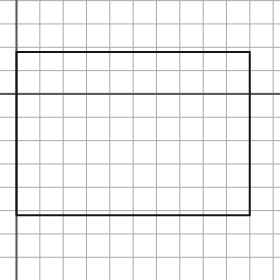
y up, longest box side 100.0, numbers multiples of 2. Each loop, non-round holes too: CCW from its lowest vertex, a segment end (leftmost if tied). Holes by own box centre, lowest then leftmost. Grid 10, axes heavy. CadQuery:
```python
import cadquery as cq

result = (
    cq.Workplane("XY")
    .moveTo(0.0, -52.0)
    .lineTo(100.0, -52.0)
    .lineTo(100.0, 18.0)
    .lineTo(0.0, 18.0)
    .close()
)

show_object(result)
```